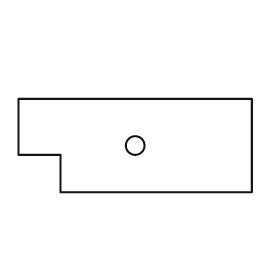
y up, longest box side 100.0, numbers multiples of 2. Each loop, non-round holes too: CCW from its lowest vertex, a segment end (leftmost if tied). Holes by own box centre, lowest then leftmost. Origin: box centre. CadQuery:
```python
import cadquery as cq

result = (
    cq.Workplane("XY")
    .moveTo(-32.0, -20.0)
    .lineTo(50.0, -20.0)
    .lineTo(50.0, 20.0)
    .lineTo(-50.0, 20.0)
    .lineTo(-50.0, -4.0)
    .lineTo(-32.0, -4.0)
    .close()
    .moveTo(0.0, 0.0)
    .circle(4.0)
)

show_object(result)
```